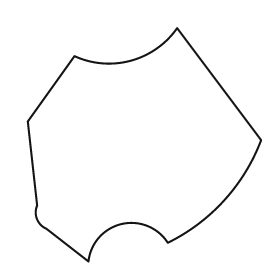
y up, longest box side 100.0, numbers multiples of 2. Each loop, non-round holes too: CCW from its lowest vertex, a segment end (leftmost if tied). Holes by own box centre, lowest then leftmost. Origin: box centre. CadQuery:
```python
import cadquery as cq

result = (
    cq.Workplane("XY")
    .moveTo(-24.0, -50.0)
    .threePointArc((-10.0, -34.0), (10.0, -42.0))
    .threePointArc((34.0, -24.0), (50.0, 2.0))
    .lineTo(14.0, 50.0)
    .threePointArc((-6.0, 36.0), (-30.0, 38.0))
    .lineTo(-50.0, 10.0)
    .lineTo(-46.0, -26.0)
    .threePointArc((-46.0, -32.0), (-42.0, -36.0))
    .close()
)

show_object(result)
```